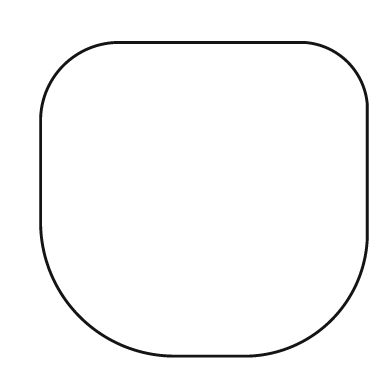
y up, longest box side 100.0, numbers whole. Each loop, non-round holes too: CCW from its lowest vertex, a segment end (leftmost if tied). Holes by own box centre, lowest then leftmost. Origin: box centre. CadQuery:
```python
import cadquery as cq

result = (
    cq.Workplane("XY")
    .moveTo(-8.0, -48.0)
    .lineTo(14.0, -48.0)
    .threePointArc((39.0, -37.0), (50.0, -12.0))
    .lineTo(50.0, 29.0)
    .threePointArc((44.0, 42.0), (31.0, 48.0))
    .lineTo(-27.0, 48.0)
    .threePointArc((-43.0, 41.0), (-50.0, 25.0))
    .lineTo(-50.0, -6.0)
    .threePointArc((-38.0, -36.0), (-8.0, -48.0))
    .close()
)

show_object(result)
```